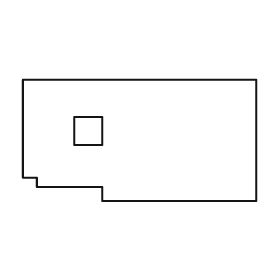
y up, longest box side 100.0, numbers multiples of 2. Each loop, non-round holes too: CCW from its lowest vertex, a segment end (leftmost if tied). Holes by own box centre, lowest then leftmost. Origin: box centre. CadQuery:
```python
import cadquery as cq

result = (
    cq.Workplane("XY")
    .moveTo(-16.0, -26.0)
    .lineTo(50.0, -26.0)
    .lineTo(50.0, 26.0)
    .lineTo(-50.0, 26.0)
    .lineTo(-50.0, -16.0)
    .lineTo(-44.0, -16.0)
    .lineTo(-44.0, -20.0)
    .lineTo(-16.0, -20.0)
    .close()
    .moveTo(-28.0, -2.0)
    .lineTo(-16.0, -2.0)
    .lineTo(-16.0, 10.0)
    .lineTo(-28.0, 10.0)
    .close()
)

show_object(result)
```